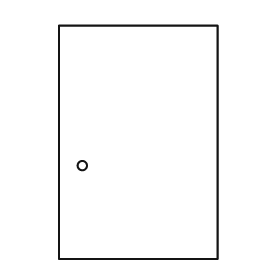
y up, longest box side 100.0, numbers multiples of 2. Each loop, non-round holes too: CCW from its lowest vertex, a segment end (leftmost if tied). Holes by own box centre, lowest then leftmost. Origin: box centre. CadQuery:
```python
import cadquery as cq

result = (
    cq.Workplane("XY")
    .moveTo(-34.0, -50.0)
    .lineTo(34.0, -50.0)
    .lineTo(34.0, 50.0)
    .lineTo(-34.0, 50.0)
    .close()
    .moveTo(-24.0, -10.0)
    .circle(2.0)
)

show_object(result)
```